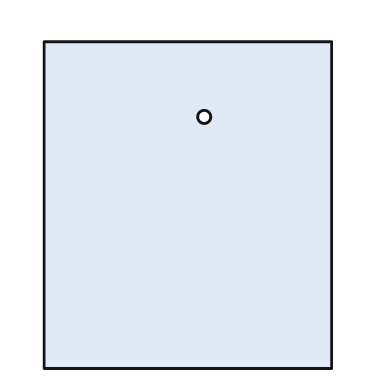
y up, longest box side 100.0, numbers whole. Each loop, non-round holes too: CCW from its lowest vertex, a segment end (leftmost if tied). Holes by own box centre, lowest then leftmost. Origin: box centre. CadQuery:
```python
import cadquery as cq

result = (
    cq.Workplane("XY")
    .moveTo(-44.0, -50.0)
    .lineTo(44.0, -50.0)
    .lineTo(44.0, 50.0)
    .lineTo(-44.0, 50.0)
    .close()
    .moveTo(5.0, 27.0)
    .circle(2.0)
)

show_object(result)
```